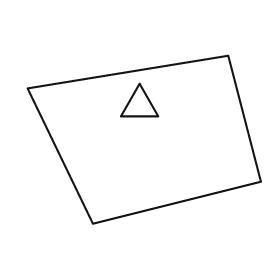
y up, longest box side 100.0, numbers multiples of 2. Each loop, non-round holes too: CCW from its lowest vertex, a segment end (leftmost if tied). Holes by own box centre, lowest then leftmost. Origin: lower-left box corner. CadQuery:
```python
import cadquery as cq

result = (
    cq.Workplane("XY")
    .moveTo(28.0, 0.0)
    .lineTo(100.0, 18.0)
    .lineTo(86.0, 72.0)
    .lineTo(0.0, 58.0)
    .close()
    .moveTo(40.0, 46.0)
    .lineTo(56.0, 46.0)
    .lineTo(48.0, 60.0)
    .close()
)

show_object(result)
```